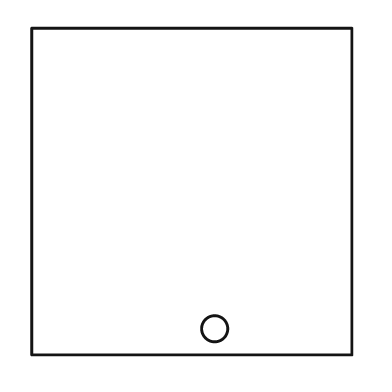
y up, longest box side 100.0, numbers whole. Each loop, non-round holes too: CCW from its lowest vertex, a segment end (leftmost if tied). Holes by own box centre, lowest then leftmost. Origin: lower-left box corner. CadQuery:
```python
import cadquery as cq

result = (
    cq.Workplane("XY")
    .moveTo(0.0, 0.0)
    .lineTo(98.0, 0.0)
    .lineTo(98.0, 100.0)
    .lineTo(0.0, 100.0)
    .close()
    .moveTo(56.0, 8.0)
    .circle(4.0)
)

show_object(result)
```